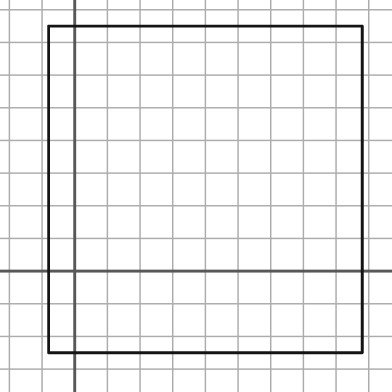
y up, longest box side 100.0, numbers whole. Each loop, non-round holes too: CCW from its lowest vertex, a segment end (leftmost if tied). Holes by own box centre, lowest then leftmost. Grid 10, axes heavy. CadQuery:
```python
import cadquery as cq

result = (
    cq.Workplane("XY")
    .moveTo(-8.0, -25.0)
    .lineTo(88.0, -25.0)
    .lineTo(88.0, 75.0)
    .lineTo(-8.0, 75.0)
    .close()
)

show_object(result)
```